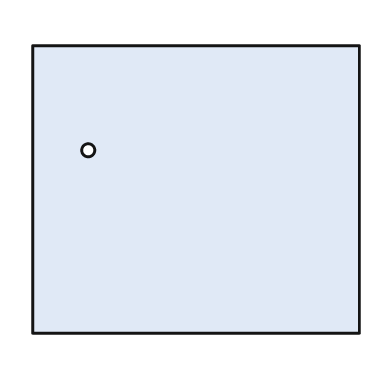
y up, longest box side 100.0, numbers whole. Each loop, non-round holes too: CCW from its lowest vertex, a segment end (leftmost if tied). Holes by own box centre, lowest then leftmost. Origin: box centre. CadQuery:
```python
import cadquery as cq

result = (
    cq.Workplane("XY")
    .moveTo(-50.0, -44.0)
    .lineTo(50.0, -44.0)
    .lineTo(50.0, 44.0)
    .lineTo(-50.0, 44.0)
    .close()
    .moveTo(-33.0, 12.0)
    .circle(2.0)
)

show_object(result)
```